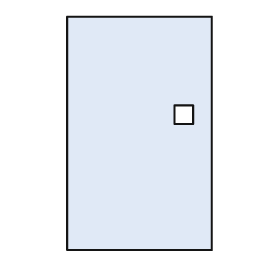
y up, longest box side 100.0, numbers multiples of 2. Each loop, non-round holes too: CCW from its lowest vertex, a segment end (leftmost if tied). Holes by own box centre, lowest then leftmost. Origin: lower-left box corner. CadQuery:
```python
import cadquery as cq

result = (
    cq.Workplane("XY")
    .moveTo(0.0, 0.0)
    .lineTo(62.0, 0.0)
    .lineTo(62.0, 100.0)
    .lineTo(0.0, 100.0)
    .close()
    .moveTo(46.0, 54.0)
    .lineTo(54.0, 54.0)
    .lineTo(54.0, 62.0)
    .lineTo(46.0, 62.0)
    .close()
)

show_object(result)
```